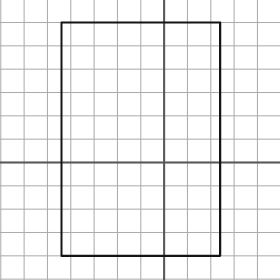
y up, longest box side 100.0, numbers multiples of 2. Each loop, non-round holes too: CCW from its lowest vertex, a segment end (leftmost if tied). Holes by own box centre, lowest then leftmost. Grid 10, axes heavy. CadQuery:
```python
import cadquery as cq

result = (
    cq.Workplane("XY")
    .moveTo(-44.0, -40.0)
    .lineTo(24.0, -40.0)
    .lineTo(24.0, 60.0)
    .lineTo(-44.0, 60.0)
    .close()
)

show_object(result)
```